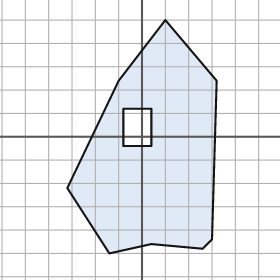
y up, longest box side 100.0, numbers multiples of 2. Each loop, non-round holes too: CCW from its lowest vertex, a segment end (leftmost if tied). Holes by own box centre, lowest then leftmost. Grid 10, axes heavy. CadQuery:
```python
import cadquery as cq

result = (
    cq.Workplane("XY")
    .moveTo(-14.0, -50.0)
    .lineTo(4.0, -46.0)
    .lineTo(26.0, -48.0)
    .lineTo(30.0, -44.0)
    .lineTo(32.0, 24.0)
    .lineTo(10.0, 50.0)
    .lineTo(-10.0, 24.0)
    .lineTo(-32.0, -22.0)
    .close()
    .moveTo(-8.0, -4.0)
    .lineTo(4.0, -4.0)
    .lineTo(4.0, 12.0)
    .lineTo(-8.0, 12.0)
    .close()
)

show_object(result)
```